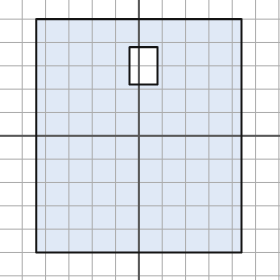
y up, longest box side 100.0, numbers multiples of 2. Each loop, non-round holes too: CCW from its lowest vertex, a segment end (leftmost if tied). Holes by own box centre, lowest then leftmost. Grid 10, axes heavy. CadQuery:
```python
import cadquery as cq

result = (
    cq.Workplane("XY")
    .moveTo(-44.0, -50.0)
    .lineTo(44.0, -50.0)
    .lineTo(44.0, 50.0)
    .lineTo(-44.0, 50.0)
    .close()
    .moveTo(-4.0, 22.0)
    .lineTo(8.0, 22.0)
    .lineTo(8.0, 38.0)
    .lineTo(-4.0, 38.0)
    .close()
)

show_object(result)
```